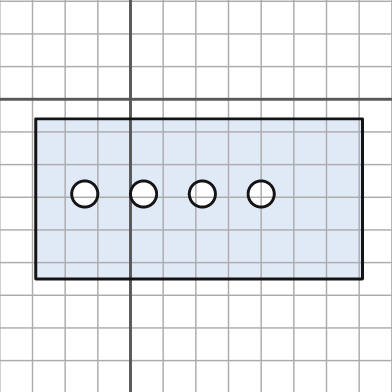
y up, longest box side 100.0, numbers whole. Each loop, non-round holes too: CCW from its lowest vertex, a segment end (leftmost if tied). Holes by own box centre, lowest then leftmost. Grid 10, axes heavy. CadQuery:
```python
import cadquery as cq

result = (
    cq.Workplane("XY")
    .moveTo(-29.0, -55.0)
    .lineTo(71.0, -55.0)
    .lineTo(71.0, -6.0)
    .lineTo(-29.0, -6.0)
    .close()
    .moveTo(-14.0, -29.0)
    .circle(4.0)
    .moveTo(4.0, -29.0)
    .circle(4.0)
    .moveTo(22.0, -29.0)
    .circle(4.0)
    .moveTo(40.0, -29.0)
    .circle(4.0)
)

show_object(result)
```